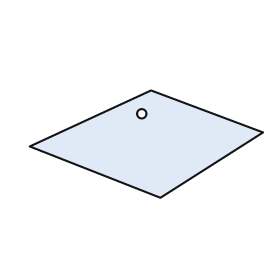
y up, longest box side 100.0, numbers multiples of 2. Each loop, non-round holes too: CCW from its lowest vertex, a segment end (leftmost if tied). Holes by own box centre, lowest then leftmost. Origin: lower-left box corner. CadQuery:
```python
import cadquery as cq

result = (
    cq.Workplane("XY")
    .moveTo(56.0, 0.0)
    .lineTo(100.0, 28.0)
    .lineTo(52.0, 46.0)
    .lineTo(0.0, 22.0)
    .close()
    .moveTo(48.0, 36.0)
    .circle(2.0)
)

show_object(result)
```